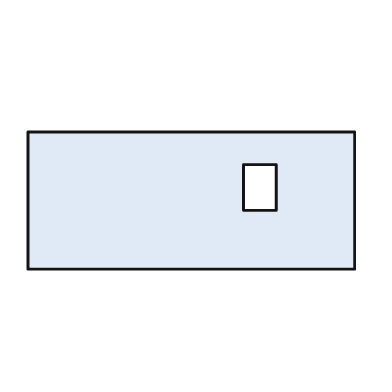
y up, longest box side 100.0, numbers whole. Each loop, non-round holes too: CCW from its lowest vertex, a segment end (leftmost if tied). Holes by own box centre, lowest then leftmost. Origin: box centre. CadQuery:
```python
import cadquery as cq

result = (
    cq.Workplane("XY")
    .moveTo(-50.0, -21.0)
    .lineTo(50.0, -21.0)
    .lineTo(50.0, 21.0)
    .lineTo(-50.0, 21.0)
    .close()
    .moveTo(16.0, -3.0)
    .lineTo(26.0, -3.0)
    .lineTo(26.0, 11.0)
    .lineTo(16.0, 11.0)
    .close()
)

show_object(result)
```